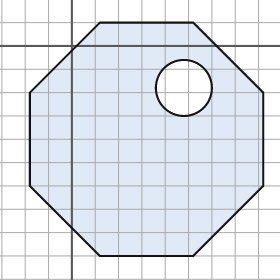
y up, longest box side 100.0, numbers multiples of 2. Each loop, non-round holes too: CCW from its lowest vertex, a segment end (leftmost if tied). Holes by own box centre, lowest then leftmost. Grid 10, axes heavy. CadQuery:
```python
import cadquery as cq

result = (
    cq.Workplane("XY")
    .moveTo(12.0, -90.0)
    .lineTo(52.0, -90.0)
    .lineTo(82.0, -60.0)
    .lineTo(82.0, -20.0)
    .lineTo(52.0, 10.0)
    .lineTo(12.0, 10.0)
    .lineTo(-18.0, -20.0)
    .lineTo(-18.0, -60.0)
    .close()
    .moveTo(48.0, -18.0)
    .circle(12.0)
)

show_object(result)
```